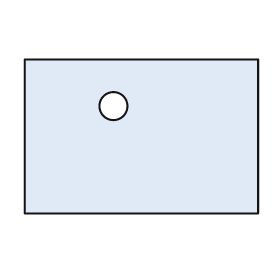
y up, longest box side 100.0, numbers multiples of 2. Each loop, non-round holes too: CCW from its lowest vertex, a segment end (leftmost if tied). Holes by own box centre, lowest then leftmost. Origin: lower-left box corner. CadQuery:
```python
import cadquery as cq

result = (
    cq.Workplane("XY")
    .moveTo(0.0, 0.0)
    .lineTo(100.0, 0.0)
    .lineTo(100.0, 66.0)
    .lineTo(0.0, 66.0)
    .close()
    .moveTo(38.0, 46.0)
    .circle(6.0)
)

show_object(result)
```